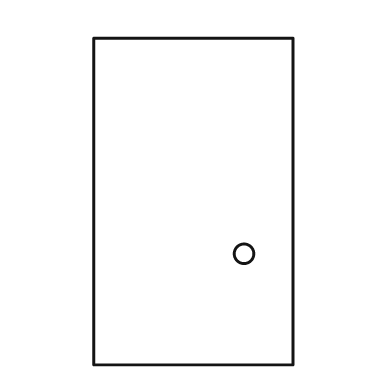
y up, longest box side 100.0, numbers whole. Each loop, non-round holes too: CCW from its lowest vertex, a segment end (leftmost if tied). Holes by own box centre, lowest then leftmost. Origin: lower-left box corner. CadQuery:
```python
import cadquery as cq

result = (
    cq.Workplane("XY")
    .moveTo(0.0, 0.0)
    .lineTo(61.0, 0.0)
    .lineTo(61.0, 100.0)
    .lineTo(0.0, 100.0)
    .close()
    .moveTo(46.0, 34.0)
    .circle(3.0)
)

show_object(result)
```